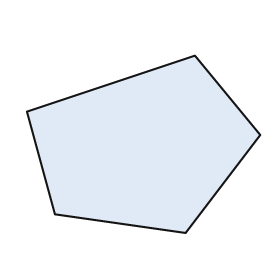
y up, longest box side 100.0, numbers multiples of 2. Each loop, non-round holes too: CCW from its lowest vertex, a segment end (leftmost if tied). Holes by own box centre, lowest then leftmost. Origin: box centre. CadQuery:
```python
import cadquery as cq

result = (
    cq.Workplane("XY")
    .moveTo(18.0, -38.0)
    .lineTo(50.0, 4.0)
    .lineTo(22.0, 38.0)
    .lineTo(-50.0, 14.0)
    .lineTo(-38.0, -30.0)
    .close()
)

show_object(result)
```